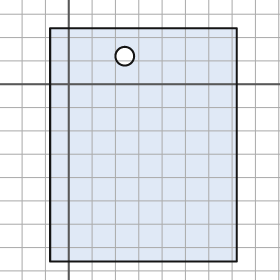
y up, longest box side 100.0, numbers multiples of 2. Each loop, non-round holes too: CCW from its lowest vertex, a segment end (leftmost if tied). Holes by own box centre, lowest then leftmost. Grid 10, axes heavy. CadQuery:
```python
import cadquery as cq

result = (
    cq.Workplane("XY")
    .moveTo(-8.0, -76.0)
    .lineTo(72.0, -76.0)
    .lineTo(72.0, 24.0)
    .lineTo(-8.0, 24.0)
    .close()
    .moveTo(24.0, 12.0)
    .circle(4.0)
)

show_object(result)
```